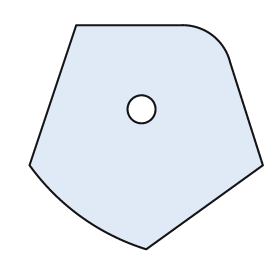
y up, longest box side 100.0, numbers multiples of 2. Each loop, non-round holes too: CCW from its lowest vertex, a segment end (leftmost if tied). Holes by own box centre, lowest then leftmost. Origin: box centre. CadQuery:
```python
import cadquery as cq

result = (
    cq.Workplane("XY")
    .moveTo(0.0, -48.0)
    .lineTo(50.0, -12.0)
    .lineTo(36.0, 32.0)
    .threePointArc((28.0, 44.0), (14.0, 48.0))
    .lineTo(-30.0, 48.0)
    .lineTo(-50.0, -12.0)
    .threePointArc((-28.0, -34.0), (0.0, -48.0))
    .close()
    .moveTo(-2.0, 12.0)
    .circle(6.0)
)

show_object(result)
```